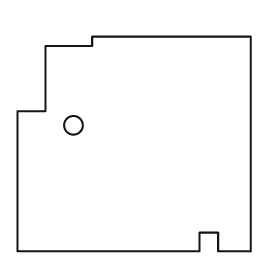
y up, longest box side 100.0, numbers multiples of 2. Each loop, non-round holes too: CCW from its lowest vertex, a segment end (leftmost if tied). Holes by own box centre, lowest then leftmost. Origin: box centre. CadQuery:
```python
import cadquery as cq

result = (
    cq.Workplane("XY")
    .moveTo(-50.0, -46.0)
    .lineTo(28.0, -46.0)
    .lineTo(28.0, -38.0)
    .lineTo(36.0, -38.0)
    .lineTo(36.0, -46.0)
    .lineTo(50.0, -46.0)
    .lineTo(50.0, 46.0)
    .lineTo(-18.0, 46.0)
    .lineTo(-18.0, 42.0)
    .lineTo(-38.0, 42.0)
    .lineTo(-38.0, 14.0)
    .lineTo(-50.0, 14.0)
    .close()
    .moveTo(-26.0, 8.0)
    .circle(4.0)
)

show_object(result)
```